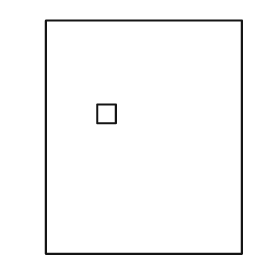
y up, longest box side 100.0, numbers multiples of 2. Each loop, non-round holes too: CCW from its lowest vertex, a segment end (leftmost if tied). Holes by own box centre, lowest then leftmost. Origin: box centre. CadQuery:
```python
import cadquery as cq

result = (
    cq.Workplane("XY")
    .moveTo(-42.0, -50.0)
    .lineTo(42.0, -50.0)
    .lineTo(42.0, 50.0)
    .lineTo(-42.0, 50.0)
    .close()
    .moveTo(-20.0, 6.0)
    .lineTo(-12.0, 6.0)
    .lineTo(-12.0, 14.0)
    .lineTo(-20.0, 14.0)
    .close()
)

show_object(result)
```